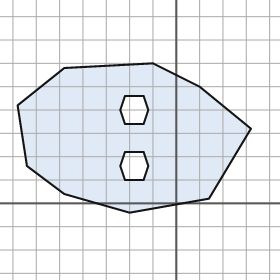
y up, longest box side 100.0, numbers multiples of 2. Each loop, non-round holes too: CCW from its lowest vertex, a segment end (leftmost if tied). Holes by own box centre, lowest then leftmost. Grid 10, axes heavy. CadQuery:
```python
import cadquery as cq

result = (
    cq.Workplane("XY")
    .moveTo(-20.0, -4.0)
    .lineTo(14.0, 2.0)
    .lineTo(32.0, 32.0)
    .lineTo(10.0, 50.0)
    .lineTo(-10.0, 60.0)
    .lineTo(-48.0, 58.0)
    .lineTo(-68.0, 42.0)
    .lineTo(-64.0, 16.0)
    .lineTo(-48.0, 4.0)
    .close()
    .moveTo(-22.0, 10.0)
    .lineTo(-14.0, 10.0)
    .lineTo(-12.0, 16.0)
    .lineTo(-14.0, 22.0)
    .lineTo(-22.0, 22.0)
    .lineTo(-24.0, 16.0)
    .close()
    .moveTo(-22.0, 34.0)
    .lineTo(-14.0, 34.0)
    .lineTo(-12.0, 40.0)
    .lineTo(-14.0, 46.0)
    .lineTo(-22.0, 46.0)
    .lineTo(-24.0, 40.0)
    .close()
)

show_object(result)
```